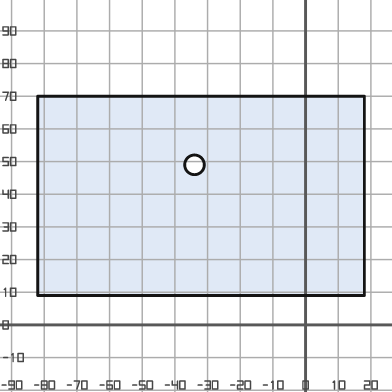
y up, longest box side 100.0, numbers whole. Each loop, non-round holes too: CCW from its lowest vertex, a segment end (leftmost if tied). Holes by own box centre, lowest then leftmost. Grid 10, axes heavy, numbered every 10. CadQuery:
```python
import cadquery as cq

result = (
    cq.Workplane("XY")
    .moveTo(-82.0, 9.0)
    .lineTo(18.0, 9.0)
    .lineTo(18.0, 70.0)
    .lineTo(-82.0, 70.0)
    .close()
    .moveTo(-34.0, 49.0)
    .circle(3.0)
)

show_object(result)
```